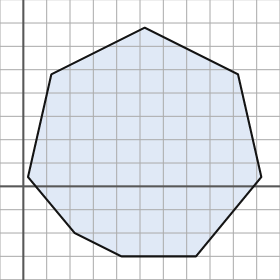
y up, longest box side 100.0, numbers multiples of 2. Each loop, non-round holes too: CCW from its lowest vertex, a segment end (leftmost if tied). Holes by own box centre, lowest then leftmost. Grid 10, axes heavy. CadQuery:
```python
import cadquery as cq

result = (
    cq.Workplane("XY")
    .moveTo(42.0, -30.0)
    .lineTo(74.0, -30.0)
    .lineTo(102.0, 4.0)
    .lineTo(92.0, 48.0)
    .lineTo(52.0, 68.0)
    .lineTo(12.0, 48.0)
    .lineTo(2.0, 4.0)
    .lineTo(22.0, -20.0)
    .close()
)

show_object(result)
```